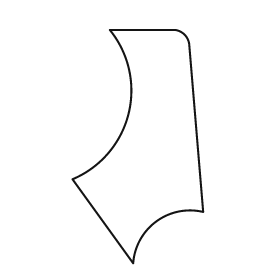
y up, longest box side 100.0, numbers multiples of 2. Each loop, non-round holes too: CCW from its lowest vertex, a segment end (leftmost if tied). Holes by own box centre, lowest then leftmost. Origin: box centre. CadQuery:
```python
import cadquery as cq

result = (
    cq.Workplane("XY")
    .moveTo(-2.0, -50.0)
    .threePointArc((8.0, -32.0), (28.0, -28.0))
    .lineTo(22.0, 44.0)
    .threePointArc((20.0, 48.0), (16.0, 50.0))
    .lineTo(-12.0, 50.0)
    .threePointArc((-4.0, 14.0), (-28.0, -14.0))
    .close()
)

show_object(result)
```